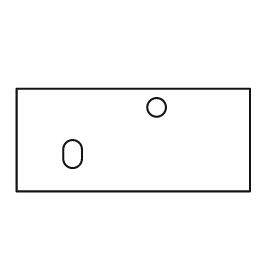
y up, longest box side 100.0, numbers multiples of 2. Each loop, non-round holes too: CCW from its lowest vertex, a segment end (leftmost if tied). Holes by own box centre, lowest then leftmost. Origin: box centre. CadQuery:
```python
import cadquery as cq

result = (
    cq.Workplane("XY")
    .moveTo(-50.0, -22.0)
    .lineTo(50.0, -22.0)
    .lineTo(50.0, 22.0)
    .lineTo(-50.0, 22.0)
    .close()
    .moveTo(-30.0, -8.0)
    .threePointArc((-26.0, -12.0), (-22.0, -8.0))
    .lineTo(-22.0, -4.0)
    .threePointArc((-26.0, 0.0), (-30.0, -4.0))
    .close()
    .moveTo(10.0, 14.0)
    .circle(4.0)
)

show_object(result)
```